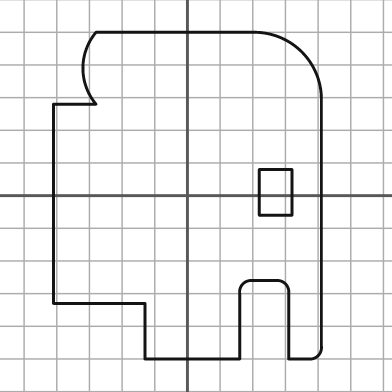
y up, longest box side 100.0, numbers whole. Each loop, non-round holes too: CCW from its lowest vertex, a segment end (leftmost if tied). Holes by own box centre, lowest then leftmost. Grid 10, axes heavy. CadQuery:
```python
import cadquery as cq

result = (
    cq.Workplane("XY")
    .moveTo(-13.0, -50.0)
    .lineTo(16.0, -50.0)
    .lineTo(16.0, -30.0)
    .threePointArc((17.0, -27.0), (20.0, -26.0))
    .lineTo(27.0, -26.0)
    .threePointArc((30.0, -27.0), (31.0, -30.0))
    .lineTo(31.0, -50.0)
    .lineTo(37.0, -50.0)
    .threePointArc((40.0, -49.0), (41.0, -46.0))
    .lineTo(41.0, 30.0)
    .threePointArc((35.0, 44.0), (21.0, 50.0))
    .lineTo(-28.0, 50.0)
    .threePointArc((-32.0, 39.0), (-28.0, 28.0))
    .lineTo(-41.0, 28.0)
    .lineTo(-41.0, -33.0)
    .lineTo(-13.0, -33.0)
    .close()
    .moveTo(22.0, -6.0)
    .lineTo(32.0, -6.0)
    .lineTo(32.0, 8.0)
    .lineTo(22.0, 8.0)
    .close()
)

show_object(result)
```